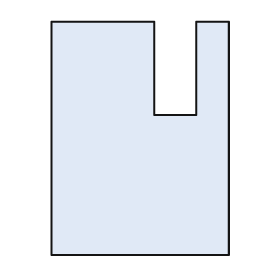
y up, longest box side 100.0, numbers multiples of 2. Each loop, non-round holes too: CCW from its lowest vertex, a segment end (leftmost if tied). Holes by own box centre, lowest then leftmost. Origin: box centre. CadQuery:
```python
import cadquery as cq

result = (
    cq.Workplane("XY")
    .moveTo(-38.0, -50.0)
    .lineTo(38.0, -50.0)
    .lineTo(38.0, 50.0)
    .lineTo(24.0, 50.0)
    .lineTo(24.0, 10.0)
    .lineTo(6.0, 10.0)
    .lineTo(6.0, 50.0)
    .lineTo(-38.0, 50.0)
    .close()
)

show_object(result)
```